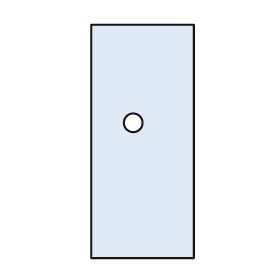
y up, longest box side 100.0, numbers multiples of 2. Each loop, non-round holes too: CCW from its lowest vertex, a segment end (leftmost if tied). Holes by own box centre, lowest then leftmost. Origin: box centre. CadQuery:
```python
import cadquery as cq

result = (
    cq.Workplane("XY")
    .moveTo(-22.0, -50.0)
    .lineTo(22.0, -50.0)
    .lineTo(22.0, 50.0)
    .lineTo(-22.0, 50.0)
    .close()
    .moveTo(-4.0, 8.0)
    .circle(4.0)
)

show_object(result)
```